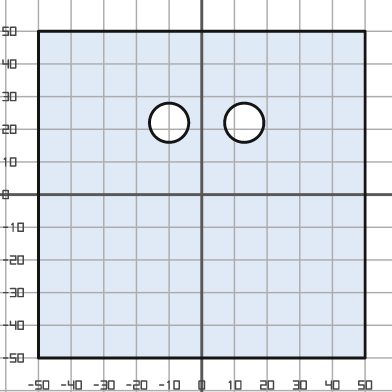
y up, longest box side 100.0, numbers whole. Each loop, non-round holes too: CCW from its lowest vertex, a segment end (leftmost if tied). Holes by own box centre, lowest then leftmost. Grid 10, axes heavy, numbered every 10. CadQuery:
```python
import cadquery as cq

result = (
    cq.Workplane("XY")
    .moveTo(-50.0, -50.0)
    .lineTo(50.0, -50.0)
    .lineTo(50.0, 50.0)
    .lineTo(-50.0, 50.0)
    .close()
    .moveTo(-10.0, 22.0)
    .circle(6.0)
    .moveTo(13.0, 22.0)
    .circle(6.0)
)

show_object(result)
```